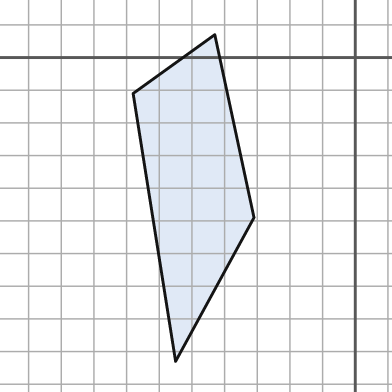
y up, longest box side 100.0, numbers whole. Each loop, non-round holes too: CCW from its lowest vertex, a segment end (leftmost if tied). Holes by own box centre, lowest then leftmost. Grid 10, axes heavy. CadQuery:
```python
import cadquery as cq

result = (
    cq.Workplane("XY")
    .moveTo(-55.0, -93.0)
    .lineTo(-31.0, -49.0)
    .lineTo(-43.0, 7.0)
    .lineTo(-68.0, -11.0)
    .close()
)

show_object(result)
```